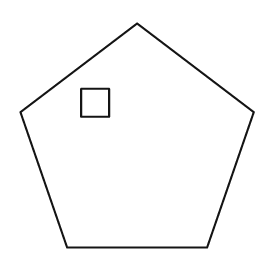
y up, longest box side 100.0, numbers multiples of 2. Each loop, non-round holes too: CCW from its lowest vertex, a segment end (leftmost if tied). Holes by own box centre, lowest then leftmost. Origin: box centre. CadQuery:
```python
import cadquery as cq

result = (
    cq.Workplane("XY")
    .moveTo(-30.0, -48.0)
    .lineTo(30.0, -48.0)
    .lineTo(50.0, 10.0)
    .lineTo(0.0, 48.0)
    .lineTo(-50.0, 10.0)
    .close()
    .moveTo(-24.0, 8.0)
    .lineTo(-12.0, 8.0)
    .lineTo(-12.0, 20.0)
    .lineTo(-24.0, 20.0)
    .close()
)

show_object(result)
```